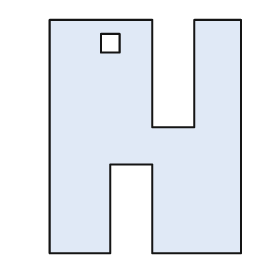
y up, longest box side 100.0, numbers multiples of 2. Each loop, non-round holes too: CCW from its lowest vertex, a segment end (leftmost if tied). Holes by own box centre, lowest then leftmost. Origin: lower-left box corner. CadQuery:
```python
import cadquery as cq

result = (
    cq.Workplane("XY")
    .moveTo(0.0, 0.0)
    .lineTo(26.0, 0.0)
    .lineTo(26.0, 38.0)
    .lineTo(44.0, 38.0)
    .lineTo(44.0, 0.0)
    .lineTo(82.0, 0.0)
    .lineTo(82.0, 100.0)
    .lineTo(62.0, 100.0)
    .lineTo(62.0, 54.0)
    .lineTo(44.0, 54.0)
    .lineTo(44.0, 100.0)
    .lineTo(0.0, 100.0)
    .close()
    .moveTo(22.0, 86.0)
    .lineTo(30.0, 86.0)
    .lineTo(30.0, 94.0)
    .lineTo(22.0, 94.0)
    .close()
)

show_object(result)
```